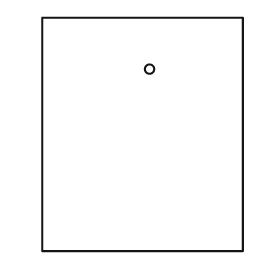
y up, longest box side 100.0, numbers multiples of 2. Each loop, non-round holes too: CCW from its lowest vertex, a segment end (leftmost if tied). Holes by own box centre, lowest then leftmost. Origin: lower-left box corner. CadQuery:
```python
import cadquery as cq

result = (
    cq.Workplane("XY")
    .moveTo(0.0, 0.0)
    .lineTo(86.0, 0.0)
    .lineTo(86.0, 100.0)
    .lineTo(0.0, 100.0)
    .close()
    .moveTo(46.0, 78.0)
    .circle(2.0)
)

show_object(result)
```